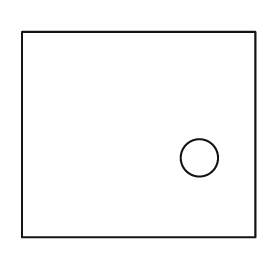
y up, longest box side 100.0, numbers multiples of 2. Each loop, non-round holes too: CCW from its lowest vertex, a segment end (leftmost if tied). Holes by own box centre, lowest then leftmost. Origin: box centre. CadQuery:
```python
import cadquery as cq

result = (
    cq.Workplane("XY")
    .moveTo(-50.0, -44.0)
    .lineTo(50.0, -44.0)
    .lineTo(50.0, 44.0)
    .lineTo(-50.0, 44.0)
    .close()
    .moveTo(26.0, -10.0)
    .circle(8.0)
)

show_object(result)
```